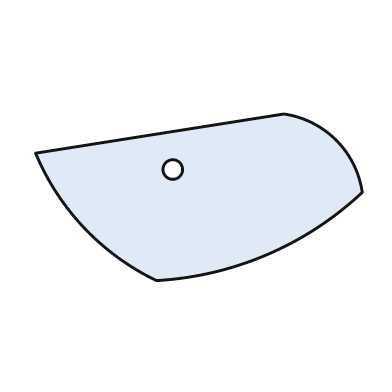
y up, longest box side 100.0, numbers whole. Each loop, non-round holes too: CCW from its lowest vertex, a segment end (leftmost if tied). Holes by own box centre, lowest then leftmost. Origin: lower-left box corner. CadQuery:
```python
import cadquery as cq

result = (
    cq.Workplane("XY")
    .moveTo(37.0, 0.0)
    .threePointArc((71.0, 8.0), (100.0, 27.0))
    .threePointArc((92.0, 43.0), (76.0, 51.0))
    .lineTo(0.0, 39.0)
    .threePointArc((15.0, 16.0), (37.0, 0.0))
    .close()
    .moveTo(42.0, 34.0)
    .circle(3.0)
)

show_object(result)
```